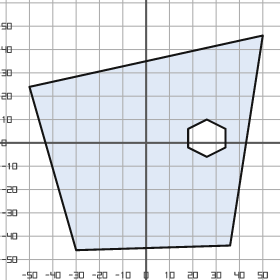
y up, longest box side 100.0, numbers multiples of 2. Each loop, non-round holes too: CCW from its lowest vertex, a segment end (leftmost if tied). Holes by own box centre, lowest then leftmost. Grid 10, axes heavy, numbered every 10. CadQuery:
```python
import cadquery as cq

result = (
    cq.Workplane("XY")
    .moveTo(-30.0, -46.0)
    .lineTo(36.0, -44.0)
    .lineTo(50.0, 46.0)
    .lineTo(-50.0, 24.0)
    .close()
    .moveTo(26.0, -6.0)
    .lineTo(34.0, -2.0)
    .lineTo(34.0, 6.0)
    .lineTo(26.0, 10.0)
    .lineTo(18.0, 6.0)
    .lineTo(18.0, -2.0)
    .close()
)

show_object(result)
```